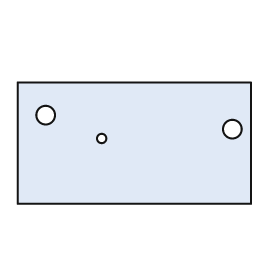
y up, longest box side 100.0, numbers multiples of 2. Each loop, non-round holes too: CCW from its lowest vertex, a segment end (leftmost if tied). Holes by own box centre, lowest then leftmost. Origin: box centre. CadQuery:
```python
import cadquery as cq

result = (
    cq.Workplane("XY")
    .moveTo(-50.0, -26.0)
    .lineTo(50.0, -26.0)
    .lineTo(50.0, 26.0)
    .lineTo(-50.0, 26.0)
    .close()
    .moveTo(-14.0, 2.0)
    .circle(2.0)
    .moveTo(42.0, 6.0)
    .circle(4.0)
    .moveTo(-38.0, 12.0)
    .circle(4.0)
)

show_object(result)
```